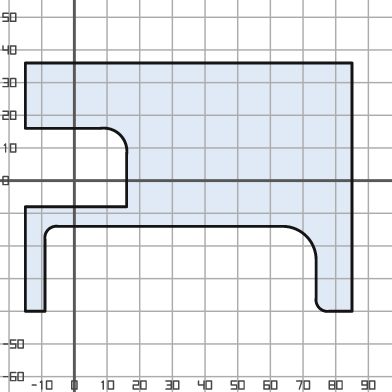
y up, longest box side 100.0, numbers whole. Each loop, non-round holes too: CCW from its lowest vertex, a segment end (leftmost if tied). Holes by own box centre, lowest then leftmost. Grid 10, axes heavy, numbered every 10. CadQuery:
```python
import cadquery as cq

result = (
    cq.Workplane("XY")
    .moveTo(-15.0, -40.0)
    .lineTo(-9.0, -40.0)
    .lineTo(-9.0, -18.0)
    .threePointArc((-8.0, -15.0), (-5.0, -14.0))
    .lineTo(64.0, -14.0)
    .threePointArc((71.0, -17.0), (74.0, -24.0))
    .lineTo(74.0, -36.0)
    .threePointArc((75.0, -39.0), (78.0, -40.0))
    .lineTo(85.0, -40.0)
    .lineTo(85.0, 36.0)
    .lineTo(-15.0, 36.0)
    .lineTo(-15.0, 16.0)
    .lineTo(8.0, 16.0)
    .threePointArc((14.0, 14.0), (16.0, 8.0))
    .lineTo(16.0, -8.0)
    .lineTo(-15.0, -8.0)
    .close()
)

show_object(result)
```